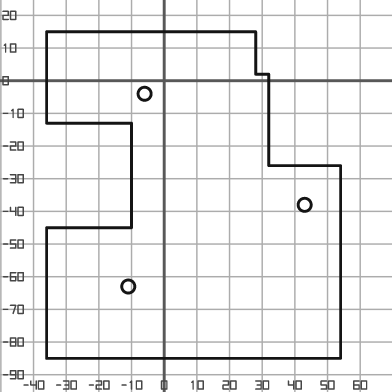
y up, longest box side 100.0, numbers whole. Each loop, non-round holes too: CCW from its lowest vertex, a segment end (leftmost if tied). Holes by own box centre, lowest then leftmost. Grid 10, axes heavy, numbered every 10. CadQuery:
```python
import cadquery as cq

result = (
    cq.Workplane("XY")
    .moveTo(-36.0, -85.0)
    .lineTo(54.0, -85.0)
    .lineTo(54.0, -26.0)
    .lineTo(32.0, -26.0)
    .lineTo(32.0, 2.0)
    .lineTo(28.0, 2.0)
    .lineTo(28.0, 15.0)
    .lineTo(-36.0, 15.0)
    .lineTo(-36.0, -13.0)
    .lineTo(-10.0, -13.0)
    .lineTo(-10.0, -45.0)
    .lineTo(-36.0, -45.0)
    .close()
    .moveTo(-11.0, -63.0)
    .circle(2.0)
    .moveTo(43.0, -38.0)
    .circle(2.0)
    .moveTo(-6.0, -4.0)
    .circle(2.0)
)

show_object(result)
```